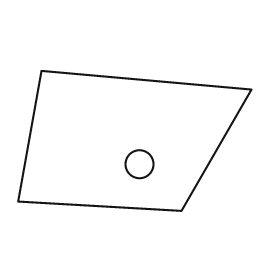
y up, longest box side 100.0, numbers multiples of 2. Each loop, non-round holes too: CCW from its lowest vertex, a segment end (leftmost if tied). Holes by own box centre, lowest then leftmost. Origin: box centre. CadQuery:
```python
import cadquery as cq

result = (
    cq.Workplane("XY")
    .moveTo(20.0, -30.0)
    .lineTo(50.0, 22.0)
    .lineTo(-40.0, 30.0)
    .lineTo(-50.0, -26.0)
    .close()
    .moveTo(2.0, -10.0)
    .circle(6.0)
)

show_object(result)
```